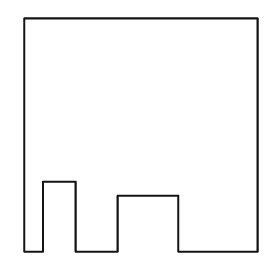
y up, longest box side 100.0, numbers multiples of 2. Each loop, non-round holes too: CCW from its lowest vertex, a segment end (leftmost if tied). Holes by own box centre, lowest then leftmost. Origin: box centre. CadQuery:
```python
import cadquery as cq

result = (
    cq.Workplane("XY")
    .moveTo(-50.0, -50.0)
    .lineTo(-42.0, -50.0)
    .lineTo(-42.0, -20.0)
    .lineTo(-28.0, -20.0)
    .lineTo(-28.0, -50.0)
    .lineTo(-10.0, -50.0)
    .lineTo(-10.0, -26.0)
    .lineTo(16.0, -26.0)
    .lineTo(16.0, -50.0)
    .lineTo(50.0, -50.0)
    .lineTo(50.0, 50.0)
    .lineTo(-50.0, 50.0)
    .close()
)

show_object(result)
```